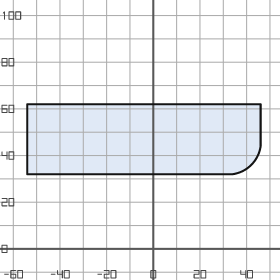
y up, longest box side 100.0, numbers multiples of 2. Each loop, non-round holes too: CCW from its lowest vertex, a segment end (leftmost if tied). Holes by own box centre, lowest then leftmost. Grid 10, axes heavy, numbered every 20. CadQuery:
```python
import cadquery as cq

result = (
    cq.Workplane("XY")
    .moveTo(-54.0, 32.0)
    .lineTo(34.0, 32.0)
    .threePointArc((42.0, 36.0), (46.0, 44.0))
    .lineTo(46.0, 62.0)
    .lineTo(-54.0, 62.0)
    .close()
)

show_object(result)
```